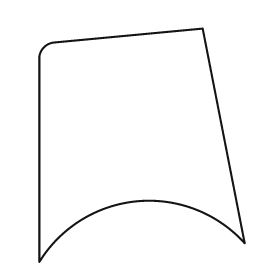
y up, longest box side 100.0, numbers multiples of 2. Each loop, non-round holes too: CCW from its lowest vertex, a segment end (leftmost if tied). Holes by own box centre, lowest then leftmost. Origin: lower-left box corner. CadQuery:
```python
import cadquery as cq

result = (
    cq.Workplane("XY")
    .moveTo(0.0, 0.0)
    .threePointArc((42.0, 26.0), (88.0, 8.0))
    .lineTo(70.0, 100.0)
    .lineTo(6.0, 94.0)
    .threePointArc((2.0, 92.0), (0.0, 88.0))
    .close()
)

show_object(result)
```